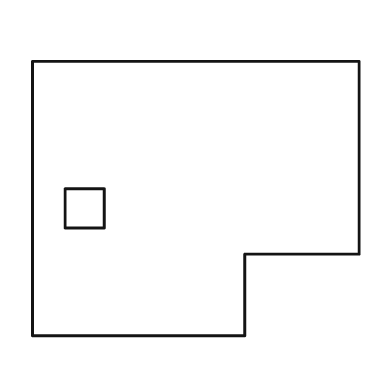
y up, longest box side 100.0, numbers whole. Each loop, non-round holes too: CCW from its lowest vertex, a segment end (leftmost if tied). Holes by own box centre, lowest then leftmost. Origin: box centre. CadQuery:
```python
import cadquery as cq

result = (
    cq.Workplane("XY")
    .moveTo(-50.0, -42.0)
    .lineTo(15.0, -42.0)
    .lineTo(15.0, -17.0)
    .lineTo(50.0, -17.0)
    .lineTo(50.0, 42.0)
    .lineTo(-50.0, 42.0)
    .close()
    .moveTo(-40.0, -9.0)
    .lineTo(-28.0, -9.0)
    .lineTo(-28.0, 3.0)
    .lineTo(-40.0, 3.0)
    .close()
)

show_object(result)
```